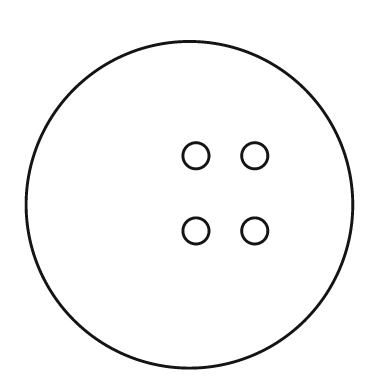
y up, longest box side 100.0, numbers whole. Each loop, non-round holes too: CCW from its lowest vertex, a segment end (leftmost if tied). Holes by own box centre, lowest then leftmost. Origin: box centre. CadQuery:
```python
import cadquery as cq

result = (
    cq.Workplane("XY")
    .moveTo(0.0, 0.0)
    .circle(50.0)
    .moveTo(2.0, -8.0)
    .circle(4.0)
    .moveTo(20.0, -8.0)
    .circle(4.0)
    .moveTo(2.0, 15.0)
    .circle(4.0)
    .moveTo(20.0, 15.0)
    .circle(4.0)
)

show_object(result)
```